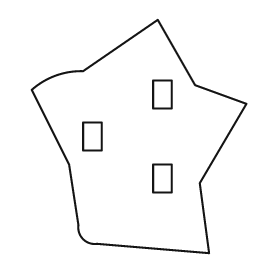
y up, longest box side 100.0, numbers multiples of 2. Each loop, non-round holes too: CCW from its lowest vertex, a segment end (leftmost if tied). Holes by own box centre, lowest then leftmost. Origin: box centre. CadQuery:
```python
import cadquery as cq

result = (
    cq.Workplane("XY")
    .moveTo(30.0, -50.0)
    .lineTo(26.0, -20.0)
    .lineTo(46.0, 14.0)
    .lineTo(24.0, 22.0)
    .lineTo(8.0, 50.0)
    .lineTo(-24.0, 28.0)
    .threePointArc((-36.0, 26.0), (-46.0, 20.0))
    .lineTo(-30.0, -12.0)
    .lineTo(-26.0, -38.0)
    .threePointArc((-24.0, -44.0), (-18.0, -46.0))
    .close()
    .moveTo(6.0, -24.0)
    .lineTo(14.0, -24.0)
    .lineTo(14.0, -12.0)
    .lineTo(6.0, -12.0)
    .close()
    .moveTo(-24.0, -6.0)
    .lineTo(-16.0, -6.0)
    .lineTo(-16.0, 6.0)
    .lineTo(-24.0, 6.0)
    .close()
    .moveTo(6.0, 12.0)
    .lineTo(14.0, 12.0)
    .lineTo(14.0, 24.0)
    .lineTo(6.0, 24.0)
    .close()
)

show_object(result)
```